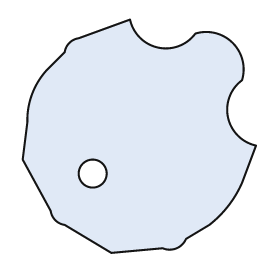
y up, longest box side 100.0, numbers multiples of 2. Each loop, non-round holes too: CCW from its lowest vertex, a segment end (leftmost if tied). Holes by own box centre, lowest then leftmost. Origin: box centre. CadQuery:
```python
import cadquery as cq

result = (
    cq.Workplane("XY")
    .moveTo(-12.0, -50.0)
    .lineTo(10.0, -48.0)
    .threePointArc((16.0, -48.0), (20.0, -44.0))
    .lineTo(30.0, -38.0)
    .threePointArc((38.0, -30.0), (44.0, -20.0))
    .lineTo(50.0, -4.0)
    .threePointArc((38.0, 8.0), (44.0, 24.0))
    .threePointArc((40.0, 40.0), (24.0, 44.0))
    .threePointArc((8.0, 38.0), (-4.0, 50.0))
    .lineTo(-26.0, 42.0)
    .threePointArc((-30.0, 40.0), (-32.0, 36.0))
    .lineTo(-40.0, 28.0)
    .threePointArc((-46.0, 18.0), (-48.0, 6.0))
    .lineTo(-50.0, -10.0)
    .lineTo(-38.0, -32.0)
    .threePointArc((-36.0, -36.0), (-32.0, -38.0))
    .close()
    .moveTo(-20.0, -16.0)
    .circle(6.0)
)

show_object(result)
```